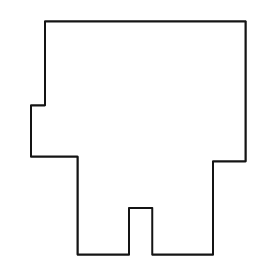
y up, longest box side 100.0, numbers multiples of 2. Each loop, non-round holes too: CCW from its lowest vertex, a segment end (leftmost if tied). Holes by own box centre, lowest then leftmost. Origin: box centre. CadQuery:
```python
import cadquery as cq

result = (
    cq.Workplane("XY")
    .moveTo(-26.0, -50.0)
    .lineTo(-4.0, -50.0)
    .lineTo(-4.0, -30.0)
    .lineTo(6.0, -30.0)
    .lineTo(6.0, -50.0)
    .lineTo(32.0, -50.0)
    .lineTo(32.0, -10.0)
    .lineTo(46.0, -10.0)
    .lineTo(46.0, 50.0)
    .lineTo(-40.0, 50.0)
    .lineTo(-40.0, 14.0)
    .lineTo(-46.0, 14.0)
    .lineTo(-46.0, -8.0)
    .lineTo(-26.0, -8.0)
    .close()
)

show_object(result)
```